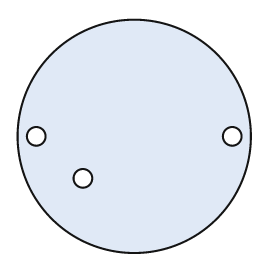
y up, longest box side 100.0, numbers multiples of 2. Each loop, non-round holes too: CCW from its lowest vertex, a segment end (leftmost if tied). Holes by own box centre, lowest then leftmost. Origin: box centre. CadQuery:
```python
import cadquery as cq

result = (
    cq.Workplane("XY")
    .moveTo(0.0, 0.0)
    .circle(50.0)
    .moveTo(-22.0, -18.0)
    .circle(4.0)
    .moveTo(-42.0, 0.0)
    .circle(4.0)
    .moveTo(42.0, 0.0)
    .circle(4.0)
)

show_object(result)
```